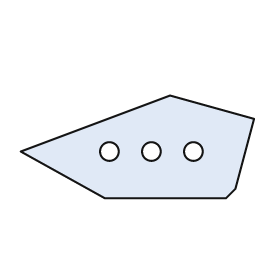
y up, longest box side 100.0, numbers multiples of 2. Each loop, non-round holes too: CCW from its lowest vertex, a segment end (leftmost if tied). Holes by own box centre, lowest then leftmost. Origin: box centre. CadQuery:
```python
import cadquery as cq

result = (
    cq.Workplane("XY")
    .moveTo(-14.0, -22.0)
    .lineTo(38.0, -22.0)
    .lineTo(42.0, -18.0)
    .lineTo(50.0, 12.0)
    .lineTo(14.0, 22.0)
    .lineTo(-50.0, -2.0)
    .close()
    .moveTo(-12.0, -2.0)
    .circle(4.0)
    .moveTo(6.0, -2.0)
    .circle(4.0)
    .moveTo(24.0, -2.0)
    .circle(4.0)
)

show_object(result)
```